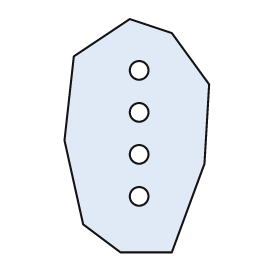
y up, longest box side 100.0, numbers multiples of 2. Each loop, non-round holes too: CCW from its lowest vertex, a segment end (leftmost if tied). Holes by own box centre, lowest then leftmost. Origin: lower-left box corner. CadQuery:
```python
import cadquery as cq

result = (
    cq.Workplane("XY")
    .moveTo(24.0, 0.0)
    .lineTo(46.0, 0.0)
    .lineTo(60.0, 38.0)
    .lineTo(62.0, 72.0)
    .lineTo(46.0, 94.0)
    .lineTo(28.0, 100.0)
    .lineTo(4.0, 84.0)
    .lineTo(0.0, 48.0)
    .lineTo(8.0, 12.0)
    .close()
    .moveTo(32.0, 24.0)
    .circle(4.0)
    .moveTo(32.0, 42.0)
    .circle(4.0)
    .moveTo(32.0, 60.0)
    .circle(4.0)
    .moveTo(32.0, 78.0)
    .circle(4.0)
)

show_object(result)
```